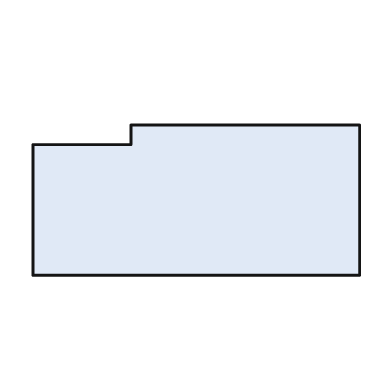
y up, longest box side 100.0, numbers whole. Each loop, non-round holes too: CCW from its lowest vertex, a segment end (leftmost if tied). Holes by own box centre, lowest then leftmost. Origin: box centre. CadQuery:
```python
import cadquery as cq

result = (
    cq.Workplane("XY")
    .moveTo(-50.0, -23.0)
    .lineTo(50.0, -23.0)
    .lineTo(50.0, 23.0)
    .lineTo(-20.0, 23.0)
    .lineTo(-20.0, 17.0)
    .lineTo(-50.0, 17.0)
    .close()
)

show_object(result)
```